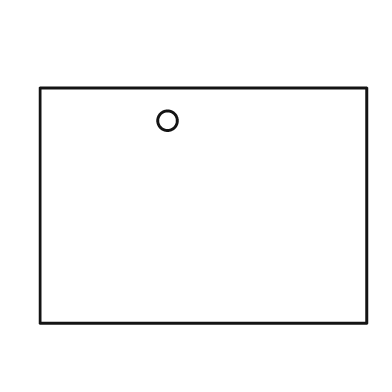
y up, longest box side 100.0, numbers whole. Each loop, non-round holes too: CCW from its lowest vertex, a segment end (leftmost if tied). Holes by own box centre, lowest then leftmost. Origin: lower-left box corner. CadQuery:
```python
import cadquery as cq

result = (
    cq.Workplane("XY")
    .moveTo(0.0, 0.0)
    .lineTo(100.0, 0.0)
    .lineTo(100.0, 72.0)
    .lineTo(0.0, 72.0)
    .close()
    .moveTo(39.0, 62.0)
    .circle(3.0)
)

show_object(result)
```